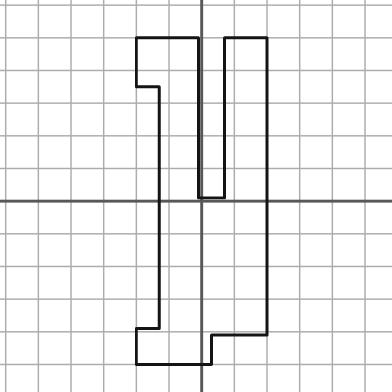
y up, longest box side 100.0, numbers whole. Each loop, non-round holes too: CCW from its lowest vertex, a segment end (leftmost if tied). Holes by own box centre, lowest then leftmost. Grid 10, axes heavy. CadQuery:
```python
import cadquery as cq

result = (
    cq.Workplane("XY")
    .moveTo(-20.0, -50.0)
    .lineTo(3.0, -50.0)
    .lineTo(3.0, -41.0)
    .lineTo(20.0, -41.0)
    .lineTo(20.0, 50.0)
    .lineTo(7.0, 50.0)
    .lineTo(7.0, 1.0)
    .lineTo(-1.0, 1.0)
    .lineTo(-1.0, 50.0)
    .lineTo(-20.0, 50.0)
    .lineTo(-20.0, 35.0)
    .lineTo(-13.0, 35.0)
    .lineTo(-13.0, -39.0)
    .lineTo(-20.0, -39.0)
    .close()
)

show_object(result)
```